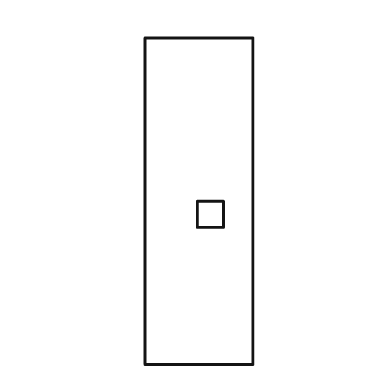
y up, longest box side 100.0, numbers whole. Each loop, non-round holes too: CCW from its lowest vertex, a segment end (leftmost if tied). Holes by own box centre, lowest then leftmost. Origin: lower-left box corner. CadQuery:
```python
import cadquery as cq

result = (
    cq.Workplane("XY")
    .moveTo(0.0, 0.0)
    .lineTo(33.0, 0.0)
    .lineTo(33.0, 100.0)
    .lineTo(0.0, 100.0)
    .close()
    .moveTo(16.0, 42.0)
    .lineTo(24.0, 42.0)
    .lineTo(24.0, 50.0)
    .lineTo(16.0, 50.0)
    .close()
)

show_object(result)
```